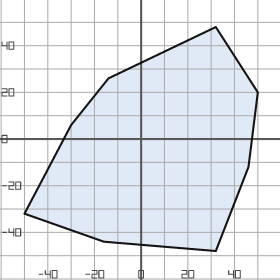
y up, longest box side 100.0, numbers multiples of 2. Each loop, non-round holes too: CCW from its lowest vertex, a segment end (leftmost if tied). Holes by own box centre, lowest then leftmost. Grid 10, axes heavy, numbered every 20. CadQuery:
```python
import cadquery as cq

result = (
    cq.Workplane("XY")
    .moveTo(32.0, -48.0)
    .lineTo(46.0, -12.0)
    .lineTo(50.0, 20.0)
    .lineTo(32.0, 48.0)
    .lineTo(-14.0, 26.0)
    .lineTo(-30.0, 6.0)
    .lineTo(-50.0, -32.0)
    .lineTo(-16.0, -44.0)
    .close()
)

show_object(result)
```